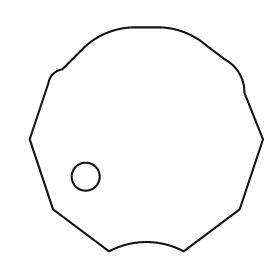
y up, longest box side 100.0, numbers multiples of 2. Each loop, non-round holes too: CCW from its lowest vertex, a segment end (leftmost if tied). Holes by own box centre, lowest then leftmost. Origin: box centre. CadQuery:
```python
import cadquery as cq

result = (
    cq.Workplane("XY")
    .moveTo(-16.0, -48.0)
    .threePointArc((0.0, -44.0), (16.0, -48.0))
    .lineTo(40.0, -30.0)
    .lineTo(50.0, 0.0)
    .lineTo(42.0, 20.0)
    .threePointArc((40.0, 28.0), (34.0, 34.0))
    .lineTo(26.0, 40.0)
    .threePointArc((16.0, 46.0), (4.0, 48.0))
    .lineTo(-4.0, 48.0)
    .threePointArc((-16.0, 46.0), (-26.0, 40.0))
    .lineTo(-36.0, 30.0)
    .threePointArc((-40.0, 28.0), (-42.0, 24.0))
    .lineTo(-50.0, 0.0)
    .lineTo(-40.0, -30.0)
    .close()
    .moveTo(-26.0, -16.0)
    .circle(6.0)
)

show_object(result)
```